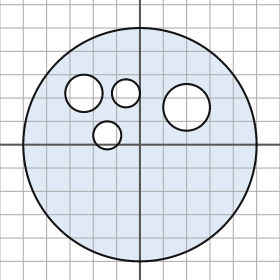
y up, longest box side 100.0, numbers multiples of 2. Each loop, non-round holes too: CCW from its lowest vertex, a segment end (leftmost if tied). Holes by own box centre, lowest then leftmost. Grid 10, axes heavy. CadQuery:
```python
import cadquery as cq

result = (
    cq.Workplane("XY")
    .moveTo(0.0, 0.0)
    .circle(50.0)
    .moveTo(-14.0, 4.0)
    .circle(6.0)
    .moveTo(20.0, 16.0)
    .circle(10.0)
    .moveTo(-24.0, 22.0)
    .circle(8.0)
    .moveTo(-6.0, 22.0)
    .circle(6.0)
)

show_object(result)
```